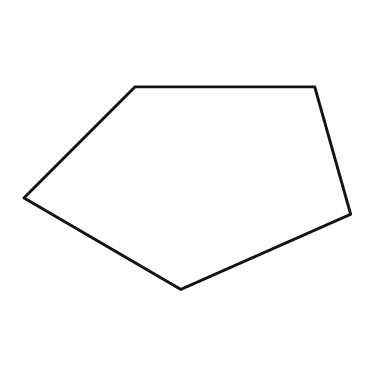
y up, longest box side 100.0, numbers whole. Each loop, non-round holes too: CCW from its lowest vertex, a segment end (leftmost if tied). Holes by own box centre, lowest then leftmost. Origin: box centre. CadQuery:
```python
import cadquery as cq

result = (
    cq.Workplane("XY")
    .moveTo(-2.0, -31.0)
    .lineTo(50.0, -8.0)
    .lineTo(39.0, 31.0)
    .lineTo(-16.0, 31.0)
    .lineTo(-50.0, -3.0)
    .close()
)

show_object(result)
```